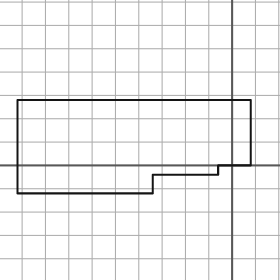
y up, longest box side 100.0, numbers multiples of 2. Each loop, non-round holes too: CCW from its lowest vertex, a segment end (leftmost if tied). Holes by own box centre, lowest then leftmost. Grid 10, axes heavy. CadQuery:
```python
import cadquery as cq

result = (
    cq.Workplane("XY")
    .moveTo(-92.0, -12.0)
    .lineTo(-34.0, -12.0)
    .lineTo(-34.0, -4.0)
    .lineTo(-6.0, -4.0)
    .lineTo(-6.0, 0.0)
    .lineTo(8.0, 0.0)
    .lineTo(8.0, 28.0)
    .lineTo(-92.0, 28.0)
    .close()
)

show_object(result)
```